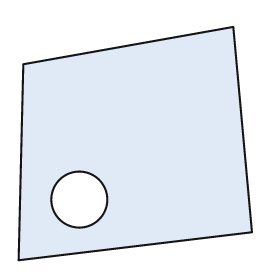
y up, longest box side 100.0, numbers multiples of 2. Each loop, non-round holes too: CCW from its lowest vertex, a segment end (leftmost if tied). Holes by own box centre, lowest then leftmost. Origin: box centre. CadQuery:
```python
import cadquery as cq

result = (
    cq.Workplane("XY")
    .moveTo(-50.0, -50.0)
    .lineTo(50.0, -38.0)
    .lineTo(42.0, 50.0)
    .lineTo(-48.0, 34.0)
    .close()
    .moveTo(-24.0, -24.0)
    .circle(12.0)
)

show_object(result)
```